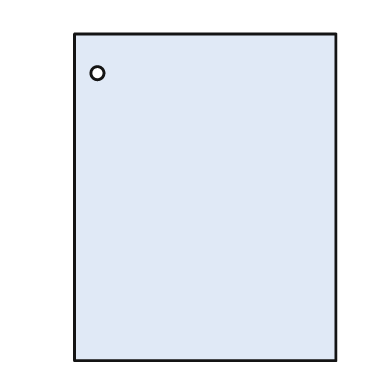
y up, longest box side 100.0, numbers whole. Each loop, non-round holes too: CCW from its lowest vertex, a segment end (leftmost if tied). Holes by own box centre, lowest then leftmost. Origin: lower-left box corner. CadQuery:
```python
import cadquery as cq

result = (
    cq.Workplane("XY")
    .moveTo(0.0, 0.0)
    .lineTo(80.0, 0.0)
    .lineTo(80.0, 100.0)
    .lineTo(0.0, 100.0)
    .close()
    .moveTo(7.0, 88.0)
    .circle(2.0)
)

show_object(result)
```